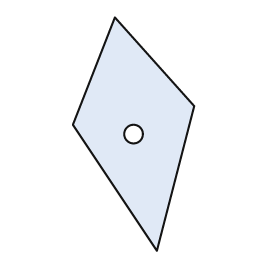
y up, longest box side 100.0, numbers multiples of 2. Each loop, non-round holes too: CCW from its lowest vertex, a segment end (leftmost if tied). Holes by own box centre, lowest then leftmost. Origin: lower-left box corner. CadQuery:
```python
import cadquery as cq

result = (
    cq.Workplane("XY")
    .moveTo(36.0, 0.0)
    .lineTo(52.0, 62.0)
    .lineTo(18.0, 100.0)
    .lineTo(0.0, 54.0)
    .close()
    .moveTo(26.0, 50.0)
    .circle(4.0)
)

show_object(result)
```